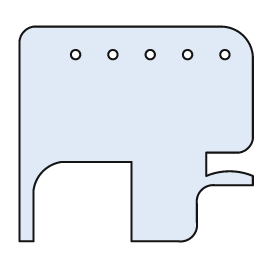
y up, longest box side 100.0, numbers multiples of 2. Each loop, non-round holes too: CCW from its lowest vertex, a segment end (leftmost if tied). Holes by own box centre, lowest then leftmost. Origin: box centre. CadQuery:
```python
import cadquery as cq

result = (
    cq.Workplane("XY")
    .moveTo(-50.0, -46.0)
    .lineTo(-44.0, -46.0)
    .lineTo(-44.0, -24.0)
    .threePointArc((-40.0, -16.0), (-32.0, -12.0))
    .lineTo(-2.0, -12.0)
    .lineTo(-2.0, -46.0)
    .lineTo(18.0, -46.0)
    .threePointArc((24.0, -44.0), (26.0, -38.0))
    .lineTo(26.0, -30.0)
    .threePointArc((28.0, -24.0), (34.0, -22.0))
    .lineTo(50.0, -22.0)
    .lineTo(50.0, -18.0)
    .threePointArc((40.0, -16.0), (30.0, -18.0))
    .lineTo(30.0, -8.0)
    .lineTo(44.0, -8.0)
    .threePointArc((48.0, -6.0), (50.0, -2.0))
    .lineTo(50.0, 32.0)
    .threePointArc((46.0, 42.0), (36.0, 46.0))
    .lineTo(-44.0, 46.0)
    .threePointArc((-48.0, 44.0), (-50.0, 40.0))
    .close()
    .moveTo(-26.0, 34.0)
    .circle(2.0)
    .moveTo(-10.0, 34.0)
    .circle(2.0)
    .moveTo(6.0, 34.0)
    .circle(2.0)
    .moveTo(22.0, 34.0)
    .circle(2.0)
    .moveTo(38.0, 34.0)
    .circle(2.0)
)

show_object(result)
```